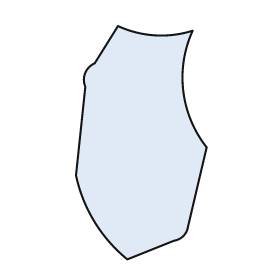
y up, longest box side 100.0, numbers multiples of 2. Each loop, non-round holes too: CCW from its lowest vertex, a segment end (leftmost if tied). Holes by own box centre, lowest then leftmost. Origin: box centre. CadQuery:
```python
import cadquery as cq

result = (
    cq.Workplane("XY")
    .moveTo(-6.0, -50.0)
    .lineTo(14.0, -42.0)
    .threePointArc((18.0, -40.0), (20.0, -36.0))
    .lineTo(28.0, -2.0)
    .threePointArc((18.0, 22.0), (22.0, 48.0))
    .threePointArc((6.0, 46.0), (-10.0, 50.0))
    .lineTo(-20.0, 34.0)
    .threePointArc((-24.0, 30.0), (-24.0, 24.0))
    .lineTo(-28.0, -14.0)
    .threePointArc((-20.0, -34.0), (-6.0, -50.0))
    .close()
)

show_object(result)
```